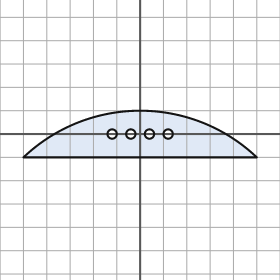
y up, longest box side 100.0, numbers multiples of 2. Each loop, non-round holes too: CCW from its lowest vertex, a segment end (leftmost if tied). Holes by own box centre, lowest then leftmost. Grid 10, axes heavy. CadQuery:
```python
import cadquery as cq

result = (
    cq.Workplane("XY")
    .moveTo(-50.0, -10.0)
    .lineTo(50.0, -10.0)
    .threePointArc((0.0, 10.0), (-50.0, -10.0))
    .close()
    .moveTo(-12.0, 0.0)
    .circle(2.0)
    .moveTo(-4.0, 0.0)
    .circle(2.0)
    .moveTo(4.0, 0.0)
    .circle(2.0)
    .moveTo(12.0, 0.0)
    .circle(2.0)
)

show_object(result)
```